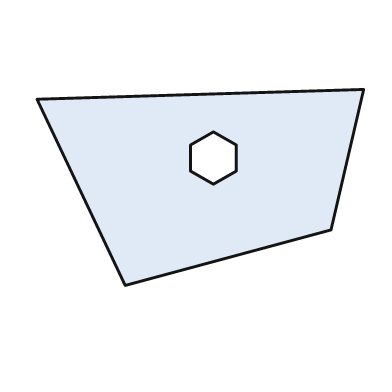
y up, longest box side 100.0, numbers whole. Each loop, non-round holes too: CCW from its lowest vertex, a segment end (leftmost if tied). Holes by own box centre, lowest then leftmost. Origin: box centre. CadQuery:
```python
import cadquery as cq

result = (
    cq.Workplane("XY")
    .moveTo(-23.0, -30.0)
    .lineTo(40.0, -13.0)
    .lineTo(50.0, 30.0)
    .lineTo(-50.0, 27.0)
    .close()
    .moveTo(4.0, 1.0)
    .lineTo(11.0, 5.0)
    .lineTo(11.0, 13.0)
    .lineTo(4.0, 17.0)
    .lineTo(-3.0, 13.0)
    .lineTo(-3.0, 5.0)
    .close()
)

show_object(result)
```